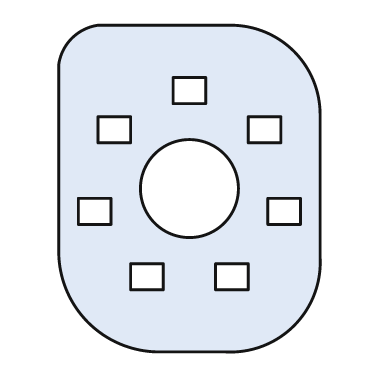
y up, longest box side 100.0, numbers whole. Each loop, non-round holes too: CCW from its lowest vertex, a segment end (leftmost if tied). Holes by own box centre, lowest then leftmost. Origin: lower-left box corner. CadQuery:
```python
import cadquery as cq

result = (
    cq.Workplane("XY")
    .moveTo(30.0, 0.0)
    .lineTo(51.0, 0.0)
    .threePointArc((72.0, 8.0), (80.0, 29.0))
    .lineTo(80.0, 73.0)
    .threePointArc((72.0, 92.0), (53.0, 100.0))
    .lineTo(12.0, 100.0)
    .threePointArc((4.0, 96.0), (0.0, 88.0))
    .lineTo(0.0, 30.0)
    .threePointArc((9.0, 9.0), (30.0, 0.0))
    .close()
    .moveTo(22.0, 19.0)
    .lineTo(32.0, 19.0)
    .lineTo(32.0, 27.0)
    .lineTo(22.0, 27.0)
    .close()
    .moveTo(48.0, 19.0)
    .lineTo(58.0, 19.0)
    .lineTo(58.0, 27.0)
    .lineTo(48.0, 27.0)
    .close()
    .moveTo(6.0, 39.0)
    .lineTo(16.0, 39.0)
    .lineTo(16.0, 47.0)
    .lineTo(6.0, 47.0)
    .close()
    .moveTo(64.0, 39.0)
    .lineTo(74.0, 39.0)
    .lineTo(74.0, 47.0)
    .lineTo(64.0, 47.0)
    .close()
    .moveTo(40.0, 50.0)
    .circle(15.0)
    .moveTo(12.0, 64.0)
    .lineTo(22.0, 64.0)
    .lineTo(22.0, 72.0)
    .lineTo(12.0, 72.0)
    .close()
    .moveTo(58.0, 64.0)
    .lineTo(68.0, 64.0)
    .lineTo(68.0, 72.0)
    .lineTo(58.0, 72.0)
    .close()
    .moveTo(35.0, 76.0)
    .lineTo(45.0, 76.0)
    .lineTo(45.0, 84.0)
    .lineTo(35.0, 84.0)
    .close()
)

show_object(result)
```